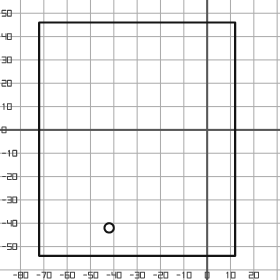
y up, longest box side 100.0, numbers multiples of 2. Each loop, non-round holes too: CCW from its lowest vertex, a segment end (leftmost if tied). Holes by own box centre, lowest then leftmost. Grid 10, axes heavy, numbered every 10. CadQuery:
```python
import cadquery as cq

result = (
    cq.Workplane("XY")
    .moveTo(-72.0, -54.0)
    .lineTo(12.0, -54.0)
    .lineTo(12.0, 46.0)
    .lineTo(-72.0, 46.0)
    .close()
    .moveTo(-42.0, -42.0)
    .circle(2.0)
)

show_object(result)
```